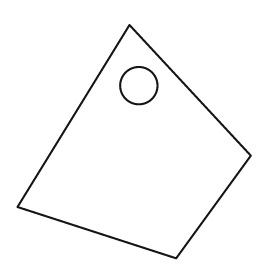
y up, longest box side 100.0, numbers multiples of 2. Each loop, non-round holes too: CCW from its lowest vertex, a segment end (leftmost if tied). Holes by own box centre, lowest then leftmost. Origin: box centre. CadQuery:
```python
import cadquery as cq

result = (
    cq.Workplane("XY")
    .moveTo(18.0, -50.0)
    .lineTo(50.0, -6.0)
    .lineTo(-2.0, 50.0)
    .lineTo(-50.0, -28.0)
    .close()
    .moveTo(2.0, 24.0)
    .circle(8.0)
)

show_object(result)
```